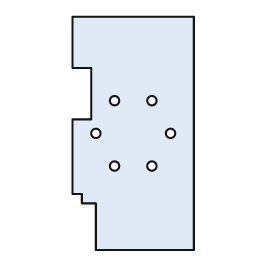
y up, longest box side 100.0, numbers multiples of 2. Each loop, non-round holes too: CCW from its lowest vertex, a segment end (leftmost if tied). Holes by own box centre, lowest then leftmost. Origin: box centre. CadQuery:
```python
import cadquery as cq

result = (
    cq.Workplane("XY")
    .moveTo(-16.0, -50.0)
    .lineTo(26.0, -50.0)
    .lineTo(26.0, 50.0)
    .lineTo(-26.0, 50.0)
    .lineTo(-26.0, 28.0)
    .lineTo(-18.0, 28.0)
    .lineTo(-18.0, 6.0)
    .lineTo(-26.0, 6.0)
    .lineTo(-26.0, -26.0)
    .lineTo(-22.0, -26.0)
    .lineTo(-22.0, -30.0)
    .lineTo(-16.0, -30.0)
    .close()
    .moveTo(-8.0, -14.0)
    .circle(2.0)
    .moveTo(8.0, -14.0)
    .circle(2.0)
    .moveTo(-16.0, 0.0)
    .circle(2.0)
    .moveTo(16.0, 0.0)
    .circle(2.0)
    .moveTo(-8.0, 14.0)
    .circle(2.0)
    .moveTo(8.0, 14.0)
    .circle(2.0)
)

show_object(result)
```